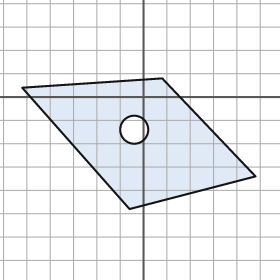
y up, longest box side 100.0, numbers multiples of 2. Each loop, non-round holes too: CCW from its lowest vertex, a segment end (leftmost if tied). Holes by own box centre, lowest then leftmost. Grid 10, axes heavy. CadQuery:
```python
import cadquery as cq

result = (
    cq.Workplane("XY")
    .moveTo(-6.0, -48.0)
    .lineTo(48.0, -34.0)
    .lineTo(8.0, 8.0)
    .lineTo(-52.0, 4.0)
    .close()
    .moveTo(-4.0, -14.0)
    .circle(6.0)
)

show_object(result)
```